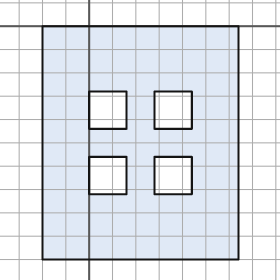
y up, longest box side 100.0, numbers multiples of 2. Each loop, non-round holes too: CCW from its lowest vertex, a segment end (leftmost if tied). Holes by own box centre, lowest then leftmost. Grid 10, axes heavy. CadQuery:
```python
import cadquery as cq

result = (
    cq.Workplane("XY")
    .moveTo(-20.0, -100.0)
    .lineTo(64.0, -100.0)
    .lineTo(64.0, 0.0)
    .lineTo(-20.0, 0.0)
    .close()
    .moveTo(0.0, -72.0)
    .lineTo(16.0, -72.0)
    .lineTo(16.0, -56.0)
    .lineTo(0.0, -56.0)
    .close()
    .moveTo(28.0, -72.0)
    .lineTo(44.0, -72.0)
    .lineTo(44.0, -56.0)
    .lineTo(28.0, -56.0)
    .close()
    .moveTo(0.0, -44.0)
    .lineTo(16.0, -44.0)
    .lineTo(16.0, -28.0)
    .lineTo(0.0, -28.0)
    .close()
    .moveTo(28.0, -44.0)
    .lineTo(44.0, -44.0)
    .lineTo(44.0, -28.0)
    .lineTo(28.0, -28.0)
    .close()
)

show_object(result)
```